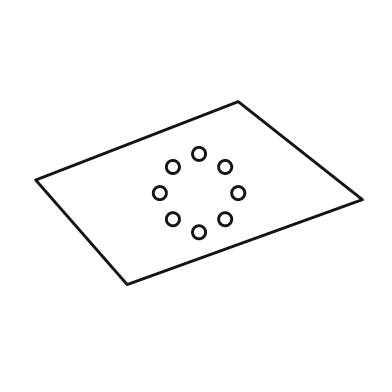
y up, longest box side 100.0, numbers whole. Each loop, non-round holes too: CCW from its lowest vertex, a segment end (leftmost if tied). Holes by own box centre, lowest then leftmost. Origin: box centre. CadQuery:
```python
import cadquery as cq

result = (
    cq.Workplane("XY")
    .moveTo(-22.0, -28.0)
    .lineTo(50.0, -2.0)
    .lineTo(12.0, 28.0)
    .lineTo(-50.0, 4.0)
    .close()
    .moveTo(0.0, -12.0)
    .circle(2.0)
    .moveTo(-8.0, -8.0)
    .circle(2.0)
    .moveTo(8.0, -8.0)
    .circle(2.0)
    .moveTo(-12.0, 0.0)
    .circle(2.0)
    .moveTo(12.0, 0.0)
    .circle(2.0)
    .moveTo(-8.0, 8.0)
    .circle(2.0)
    .moveTo(8.0, 8.0)
    .circle(2.0)
    .moveTo(0.0, 12.0)
    .circle(2.0)
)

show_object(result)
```